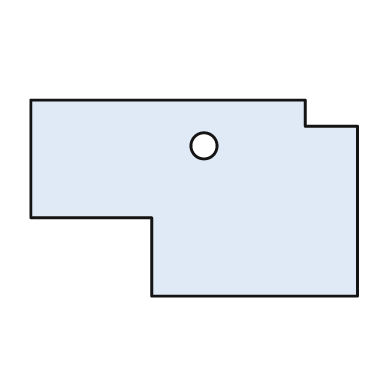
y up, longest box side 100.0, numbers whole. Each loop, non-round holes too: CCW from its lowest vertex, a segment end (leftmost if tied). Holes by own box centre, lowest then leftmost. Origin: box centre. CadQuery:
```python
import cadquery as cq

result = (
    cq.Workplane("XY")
    .moveTo(-13.0, -30.0)
    .lineTo(50.0, -30.0)
    .lineTo(50.0, 22.0)
    .lineTo(34.0, 22.0)
    .lineTo(34.0, 30.0)
    .lineTo(-50.0, 30.0)
    .lineTo(-50.0, -6.0)
    .lineTo(-13.0, -6.0)
    .close()
    .moveTo(3.0, 16.0)
    .circle(4.0)
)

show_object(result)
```